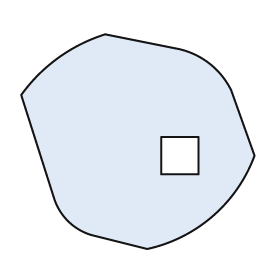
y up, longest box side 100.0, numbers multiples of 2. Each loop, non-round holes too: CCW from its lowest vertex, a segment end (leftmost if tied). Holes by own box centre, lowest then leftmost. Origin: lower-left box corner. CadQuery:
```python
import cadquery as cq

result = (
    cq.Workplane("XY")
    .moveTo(54.0, 0.0)
    .threePointArc((82.0, 14.0), (100.0, 40.0))
    .lineTo(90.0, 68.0)
    .threePointArc((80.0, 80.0), (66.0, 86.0))
    .lineTo(36.0, 92.0)
    .threePointArc((16.0, 82.0), (0.0, 66.0))
    .lineTo(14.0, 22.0)
    .threePointArc((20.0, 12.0), (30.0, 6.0))
    .close()
    .moveTo(60.0, 32.0)
    .lineTo(76.0, 32.0)
    .lineTo(76.0, 48.0)
    .lineTo(60.0, 48.0)
    .close()
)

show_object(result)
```